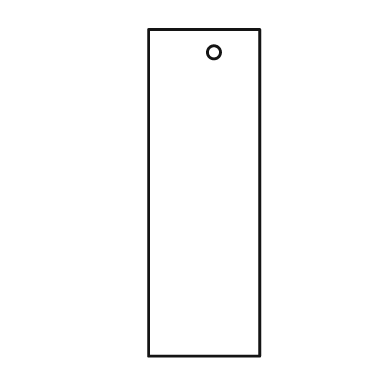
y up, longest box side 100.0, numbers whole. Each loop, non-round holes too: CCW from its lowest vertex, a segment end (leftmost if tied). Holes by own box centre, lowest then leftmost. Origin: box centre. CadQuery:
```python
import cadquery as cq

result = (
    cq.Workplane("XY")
    .moveTo(-17.0, -50.0)
    .lineTo(17.0, -50.0)
    .lineTo(17.0, 50.0)
    .lineTo(-17.0, 50.0)
    .close()
    .moveTo(3.0, 43.0)
    .circle(2.0)
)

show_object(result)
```